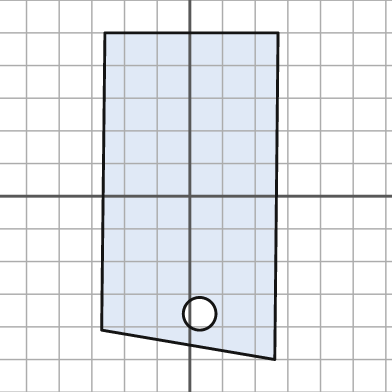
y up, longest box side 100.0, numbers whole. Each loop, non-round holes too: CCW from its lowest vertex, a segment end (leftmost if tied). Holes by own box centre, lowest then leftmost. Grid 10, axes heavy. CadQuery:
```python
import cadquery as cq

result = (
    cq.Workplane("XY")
    .moveTo(26.0, -50.0)
    .lineTo(27.0, 50.0)
    .lineTo(-26.0, 50.0)
    .lineTo(-27.0, -41.0)
    .close()
    .moveTo(3.0, -36.0)
    .circle(5.0)
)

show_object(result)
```